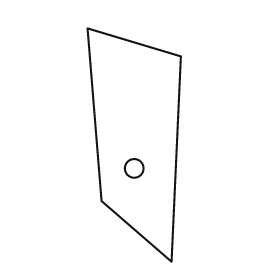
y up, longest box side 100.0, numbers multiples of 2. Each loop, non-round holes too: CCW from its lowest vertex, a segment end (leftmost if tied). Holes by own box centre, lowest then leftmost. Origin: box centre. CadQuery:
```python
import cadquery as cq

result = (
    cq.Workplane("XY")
    .moveTo(16.0, -50.0)
    .lineTo(20.0, 38.0)
    .lineTo(-20.0, 50.0)
    .lineTo(-14.0, -24.0)
    .close()
    .moveTo(0.0, -10.0)
    .circle(4.0)
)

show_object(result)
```